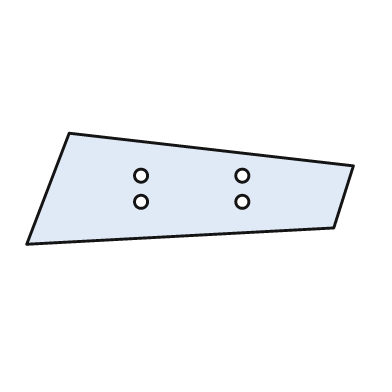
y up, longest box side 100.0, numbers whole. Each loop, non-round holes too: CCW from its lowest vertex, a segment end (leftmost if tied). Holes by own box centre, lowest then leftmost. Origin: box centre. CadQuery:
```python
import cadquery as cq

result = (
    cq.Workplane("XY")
    .moveTo(-50.0, -17.0)
    .lineTo(44.0, -12.0)
    .lineTo(50.0, 7.0)
    .lineTo(-37.0, 17.0)
    .close()
    .moveTo(-15.0, -4.0)
    .circle(2.0)
    .moveTo(16.0, -4.0)
    .circle(2.0)
    .moveTo(-15.0, 4.0)
    .circle(2.0)
    .moveTo(16.0, 4.0)
    .circle(2.0)
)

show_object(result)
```